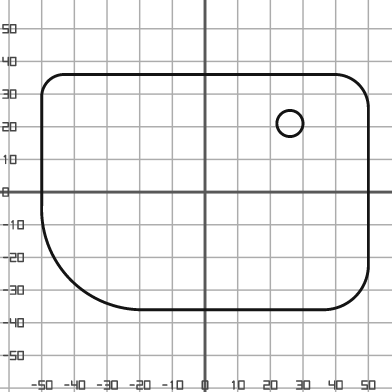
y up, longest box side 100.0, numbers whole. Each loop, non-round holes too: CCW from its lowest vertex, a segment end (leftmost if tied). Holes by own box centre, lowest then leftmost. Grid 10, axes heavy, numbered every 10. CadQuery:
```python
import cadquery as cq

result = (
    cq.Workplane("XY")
    .moveTo(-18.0, -36.0)
    .lineTo(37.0, -36.0)
    .threePointArc((46.0, -32.0), (50.0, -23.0))
    .lineTo(50.0, 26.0)
    .threePointArc((47.0, 33.0), (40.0, 36.0))
    .lineTo(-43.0, 36.0)
    .threePointArc((-48.0, 34.0), (-50.0, 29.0))
    .lineTo(-50.0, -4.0)
    .threePointArc((-41.0, -27.0), (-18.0, -36.0))
    .close()
    .moveTo(26.0, 21.0)
    .circle(4.0)
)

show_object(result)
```